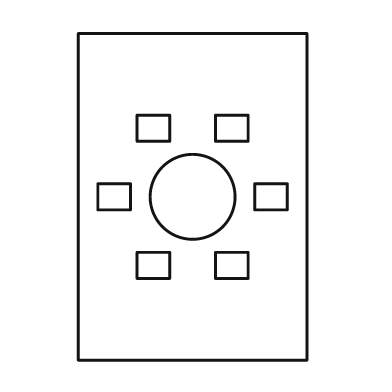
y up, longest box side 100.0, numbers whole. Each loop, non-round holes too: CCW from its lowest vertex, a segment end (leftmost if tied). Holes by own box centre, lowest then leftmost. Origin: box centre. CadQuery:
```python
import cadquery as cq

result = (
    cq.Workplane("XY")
    .moveTo(-35.0, -50.0)
    .lineTo(35.0, -50.0)
    .lineTo(35.0, 50.0)
    .lineTo(-35.0, 50.0)
    .close()
    .moveTo(-17.0, -25.0)
    .lineTo(-7.0, -25.0)
    .lineTo(-7.0, -17.0)
    .lineTo(-17.0, -17.0)
    .close()
    .moveTo(7.0, -25.0)
    .lineTo(17.0, -25.0)
    .lineTo(17.0, -17.0)
    .lineTo(7.0, -17.0)
    .close()
    .moveTo(-29.0, -4.0)
    .lineTo(-19.0, -4.0)
    .lineTo(-19.0, 4.0)
    .lineTo(-29.0, 4.0)
    .close()
    .moveTo(0.0, 0.0)
    .circle(13.0)
    .moveTo(19.0, -4.0)
    .lineTo(29.0, -4.0)
    .lineTo(29.0, 4.0)
    .lineTo(19.0, 4.0)
    .close()
    .moveTo(-17.0, 17.0)
    .lineTo(-7.0, 17.0)
    .lineTo(-7.0, 25.0)
    .lineTo(-17.0, 25.0)
    .close()
    .moveTo(7.0, 17.0)
    .lineTo(17.0, 17.0)
    .lineTo(17.0, 25.0)
    .lineTo(7.0, 25.0)
    .close()
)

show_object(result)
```